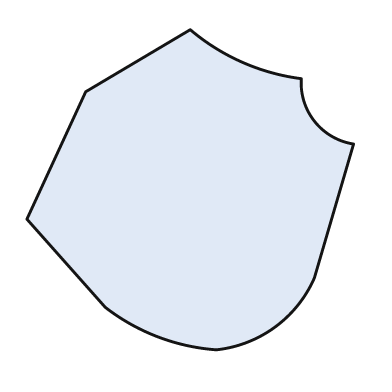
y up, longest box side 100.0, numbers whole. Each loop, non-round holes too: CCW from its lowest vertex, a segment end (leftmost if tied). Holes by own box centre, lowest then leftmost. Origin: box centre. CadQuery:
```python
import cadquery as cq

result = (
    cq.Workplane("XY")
    .moveTo(8.0, -49.0)
    .threePointArc((26.0, -42.0), (38.0, -27.0))
    .lineTo(50.0, 14.0)
    .threePointArc((38.0, 21.0), (34.0, 34.0))
    .threePointArc((16.0, 39.0), (0.0, 49.0))
    .lineTo(-32.0, 30.0)
    .lineTo(-50.0, -9.0)
    .lineTo(-26.0, -36.0)
    .threePointArc((-10.0, -45.0), (8.0, -49.0))
    .close()
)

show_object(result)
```